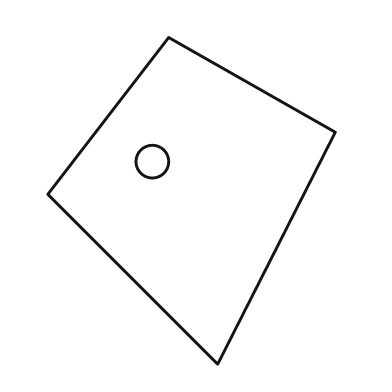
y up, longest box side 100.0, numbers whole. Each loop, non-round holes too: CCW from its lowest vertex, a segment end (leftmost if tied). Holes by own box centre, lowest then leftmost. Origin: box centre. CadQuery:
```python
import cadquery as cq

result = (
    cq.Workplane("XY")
    .moveTo(8.0, -50.0)
    .lineTo(44.0, 21.0)
    .lineTo(-7.0, 50.0)
    .lineTo(-44.0, 2.0)
    .close()
    .moveTo(-12.0, 12.0)
    .circle(5.0)
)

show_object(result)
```